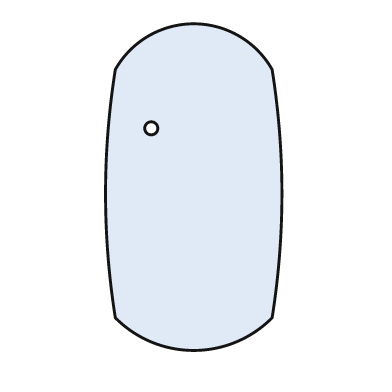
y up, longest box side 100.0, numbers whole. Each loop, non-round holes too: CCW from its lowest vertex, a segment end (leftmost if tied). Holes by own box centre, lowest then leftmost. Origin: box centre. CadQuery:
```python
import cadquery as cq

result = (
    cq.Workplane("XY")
    .moveTo(-24.0, -40.0)
    .threePointArc((0.0, -50.0), (24.0, -40.0))
    .threePointArc((27.0, -2.0), (24.0, 36.0))
    .threePointArc((0.0, 50.0), (-24.0, 36.0))
    .threePointArc((-27.0, -2.0), (-24.0, -40.0))
    .close()
    .moveTo(-13.0, 18.0)
    .circle(2.0)
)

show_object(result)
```